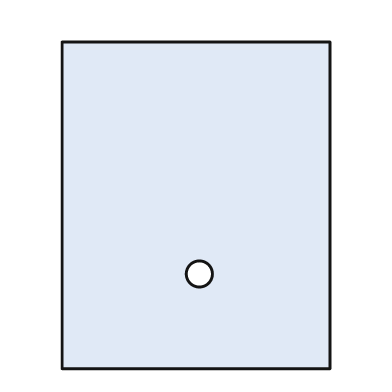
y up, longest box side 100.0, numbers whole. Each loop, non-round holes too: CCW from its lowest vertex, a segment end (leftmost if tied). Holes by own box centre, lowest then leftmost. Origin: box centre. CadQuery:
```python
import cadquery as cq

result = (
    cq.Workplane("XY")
    .moveTo(-41.0, -50.0)
    .lineTo(41.0, -50.0)
    .lineTo(41.0, 50.0)
    .lineTo(-41.0, 50.0)
    .close()
    .moveTo(1.0, -21.0)
    .circle(4.0)
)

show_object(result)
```